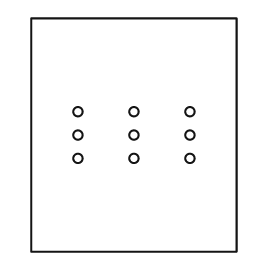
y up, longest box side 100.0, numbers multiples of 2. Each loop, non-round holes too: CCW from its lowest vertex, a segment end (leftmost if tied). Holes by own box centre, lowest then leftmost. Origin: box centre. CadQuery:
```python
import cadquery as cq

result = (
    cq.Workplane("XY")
    .moveTo(-44.0, -50.0)
    .lineTo(44.0, -50.0)
    .lineTo(44.0, 50.0)
    .lineTo(-44.0, 50.0)
    .close()
    .moveTo(-24.0, -10.0)
    .circle(2.0)
    .moveTo(0.0, -10.0)
    .circle(2.0)
    .moveTo(24.0, -10.0)
    .circle(2.0)
    .moveTo(-24.0, 0.0)
    .circle(2.0)
    .moveTo(0.0, 0.0)
    .circle(2.0)
    .moveTo(24.0, 0.0)
    .circle(2.0)
    .moveTo(-24.0, 10.0)
    .circle(2.0)
    .moveTo(0.0, 10.0)
    .circle(2.0)
    .moveTo(24.0, 10.0)
    .circle(2.0)
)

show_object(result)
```